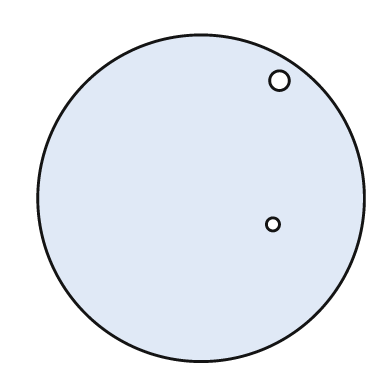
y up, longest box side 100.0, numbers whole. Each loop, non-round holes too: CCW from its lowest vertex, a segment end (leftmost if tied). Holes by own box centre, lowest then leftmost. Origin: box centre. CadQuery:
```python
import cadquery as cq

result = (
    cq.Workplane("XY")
    .moveTo(0.0, 0.0)
    .circle(50.0)
    .moveTo(22.0, -8.0)
    .circle(2.0)
    .moveTo(24.0, 36.0)
    .circle(3.0)
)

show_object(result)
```